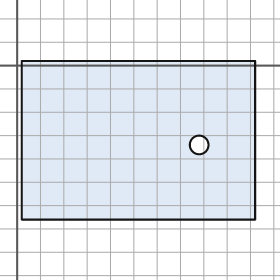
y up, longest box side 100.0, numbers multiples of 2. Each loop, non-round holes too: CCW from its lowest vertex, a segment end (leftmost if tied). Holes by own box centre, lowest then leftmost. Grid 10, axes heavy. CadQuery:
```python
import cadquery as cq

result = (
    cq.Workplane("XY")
    .moveTo(2.0, -66.0)
    .lineTo(102.0, -66.0)
    .lineTo(102.0, 2.0)
    .lineTo(2.0, 2.0)
    .close()
    .moveTo(78.0, -34.0)
    .circle(4.0)
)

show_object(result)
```